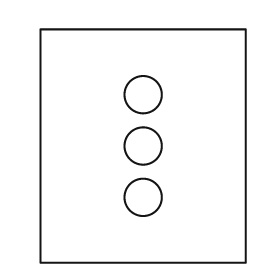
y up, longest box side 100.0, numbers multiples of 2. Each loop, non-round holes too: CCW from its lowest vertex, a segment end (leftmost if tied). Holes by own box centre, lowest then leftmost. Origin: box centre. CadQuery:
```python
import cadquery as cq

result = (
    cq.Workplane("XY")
    .moveTo(-44.0, -50.0)
    .lineTo(44.0, -50.0)
    .lineTo(44.0, 50.0)
    .lineTo(-44.0, 50.0)
    .close()
    .moveTo(0.0, -22.0)
    .circle(8.0)
    .moveTo(0.0, 0.0)
    .circle(8.0)
    .moveTo(0.0, 22.0)
    .circle(8.0)
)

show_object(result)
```